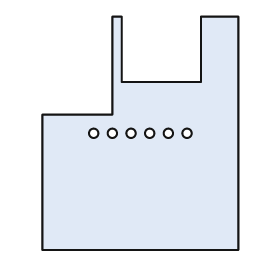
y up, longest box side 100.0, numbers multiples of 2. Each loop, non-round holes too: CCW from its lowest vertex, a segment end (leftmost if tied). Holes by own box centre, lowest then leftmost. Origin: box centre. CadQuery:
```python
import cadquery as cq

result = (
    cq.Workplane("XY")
    .moveTo(-42.0, -50.0)
    .lineTo(42.0, -50.0)
    .lineTo(42.0, 50.0)
    .lineTo(26.0, 50.0)
    .lineTo(26.0, 22.0)
    .lineTo(-8.0, 22.0)
    .lineTo(-8.0, 50.0)
    .lineTo(-12.0, 50.0)
    .lineTo(-12.0, 8.0)
    .lineTo(-42.0, 8.0)
    .close()
    .moveTo(-20.0, 0.0)
    .circle(2.0)
    .moveTo(-12.0, 0.0)
    .circle(2.0)
    .moveTo(-4.0, 0.0)
    .circle(2.0)
    .moveTo(4.0, 0.0)
    .circle(2.0)
    .moveTo(12.0, 0.0)
    .circle(2.0)
    .moveTo(20.0, 0.0)
    .circle(2.0)
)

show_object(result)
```